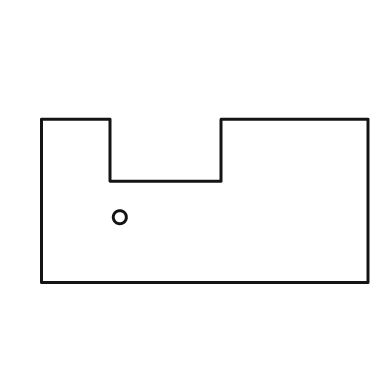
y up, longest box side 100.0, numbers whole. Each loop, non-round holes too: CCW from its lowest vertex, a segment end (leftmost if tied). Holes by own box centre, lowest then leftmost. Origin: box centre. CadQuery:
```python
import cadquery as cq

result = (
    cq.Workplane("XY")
    .moveTo(-50.0, -25.0)
    .lineTo(50.0, -25.0)
    .lineTo(50.0, 25.0)
    .lineTo(5.0, 25.0)
    .lineTo(5.0, 6.0)
    .lineTo(-29.0, 6.0)
    .lineTo(-29.0, 25.0)
    .lineTo(-50.0, 25.0)
    .close()
    .moveTo(-26.0, -5.0)
    .circle(2.0)
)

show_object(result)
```